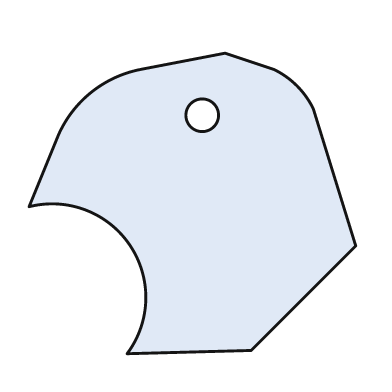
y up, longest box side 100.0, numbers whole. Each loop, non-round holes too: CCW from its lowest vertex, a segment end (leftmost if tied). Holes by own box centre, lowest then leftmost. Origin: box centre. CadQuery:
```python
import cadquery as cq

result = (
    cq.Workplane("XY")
    .moveTo(-20.0, -46.0)
    .lineTo(18.0, -45.0)
    .lineTo(50.0, -13.0)
    .lineTo(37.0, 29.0)
    .threePointArc((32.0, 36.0), (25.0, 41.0))
    .lineTo(10.0, 46.0)
    .lineTo(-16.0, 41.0)
    .threePointArc((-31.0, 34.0), (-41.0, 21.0))
    .lineTo(-50.0, -1.0)
    .threePointArc((-19.0, -13.0), (-20.0, -46.0))
    .close()
    .moveTo(3.0, 27.0)
    .circle(5.0)
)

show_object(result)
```